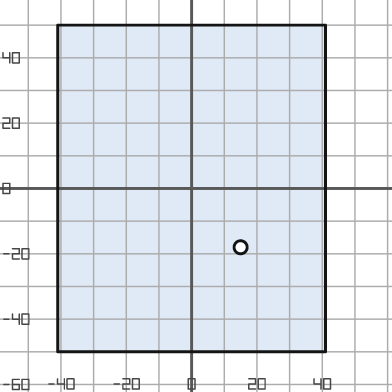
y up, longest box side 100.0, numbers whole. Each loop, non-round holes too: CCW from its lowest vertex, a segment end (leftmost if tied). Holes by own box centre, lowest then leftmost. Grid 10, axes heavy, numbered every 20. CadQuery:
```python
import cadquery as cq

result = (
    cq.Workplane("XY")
    .moveTo(-41.0, -50.0)
    .lineTo(41.0, -50.0)
    .lineTo(41.0, 50.0)
    .lineTo(-41.0, 50.0)
    .close()
    .moveTo(15.0, -18.0)
    .circle(2.0)
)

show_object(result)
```